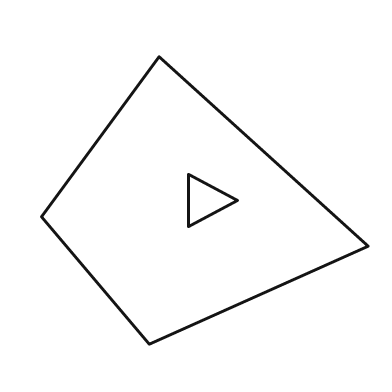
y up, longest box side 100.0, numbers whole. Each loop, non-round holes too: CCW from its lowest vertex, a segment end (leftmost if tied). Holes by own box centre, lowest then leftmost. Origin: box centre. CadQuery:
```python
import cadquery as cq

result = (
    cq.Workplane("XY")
    .moveTo(-17.0, -44.0)
    .lineTo(50.0, -14.0)
    .lineTo(-14.0, 44.0)
    .lineTo(-50.0, -5.0)
    .close()
    .moveTo(-5.0, -8.0)
    .lineTo(10.0, 0.0)
    .lineTo(-5.0, 8.0)
    .close()
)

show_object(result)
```